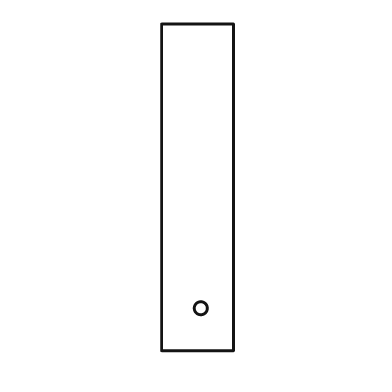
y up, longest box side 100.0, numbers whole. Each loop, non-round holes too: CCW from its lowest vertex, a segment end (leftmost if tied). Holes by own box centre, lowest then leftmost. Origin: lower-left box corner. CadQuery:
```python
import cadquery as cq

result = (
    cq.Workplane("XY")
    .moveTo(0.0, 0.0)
    .lineTo(22.0, 0.0)
    .lineTo(22.0, 100.0)
    .lineTo(0.0, 100.0)
    .close()
    .moveTo(12.0, 13.0)
    .circle(2.0)
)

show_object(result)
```